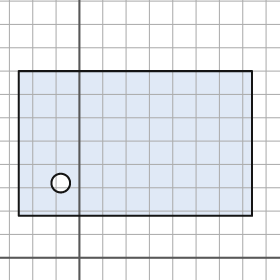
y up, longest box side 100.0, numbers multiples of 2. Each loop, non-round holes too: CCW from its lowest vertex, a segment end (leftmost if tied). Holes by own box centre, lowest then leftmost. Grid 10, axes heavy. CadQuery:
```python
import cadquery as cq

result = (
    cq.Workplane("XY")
    .moveTo(-26.0, 18.0)
    .lineTo(74.0, 18.0)
    .lineTo(74.0, 80.0)
    .lineTo(-26.0, 80.0)
    .close()
    .moveTo(-8.0, 32.0)
    .circle(4.0)
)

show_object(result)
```